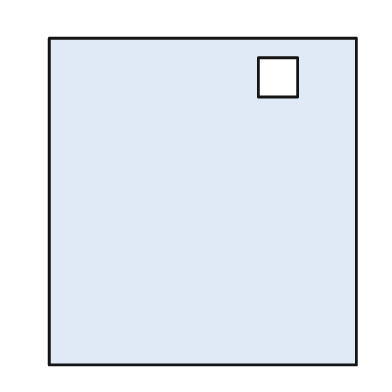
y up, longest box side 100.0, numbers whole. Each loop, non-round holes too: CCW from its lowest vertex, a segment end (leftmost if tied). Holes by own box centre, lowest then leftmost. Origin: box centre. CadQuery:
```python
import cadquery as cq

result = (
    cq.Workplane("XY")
    .moveTo(-47.0, -50.0)
    .lineTo(47.0, -50.0)
    .lineTo(47.0, 50.0)
    .lineTo(-47.0, 50.0)
    .close()
    .moveTo(17.0, 32.0)
    .lineTo(29.0, 32.0)
    .lineTo(29.0, 44.0)
    .lineTo(17.0, 44.0)
    .close()
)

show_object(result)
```